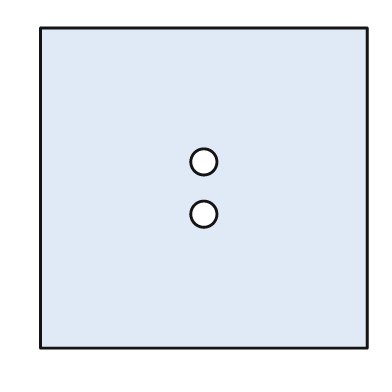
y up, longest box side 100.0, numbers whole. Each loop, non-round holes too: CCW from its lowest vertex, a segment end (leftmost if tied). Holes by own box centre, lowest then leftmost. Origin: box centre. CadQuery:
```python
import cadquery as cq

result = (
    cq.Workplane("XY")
    .moveTo(-50.0, -49.0)
    .lineTo(50.0, -49.0)
    .lineTo(50.0, 49.0)
    .lineTo(-50.0, 49.0)
    .close()
    .moveTo(0.0, -8.0)
    .circle(4.0)
    .moveTo(0.0, 8.0)
    .circle(4.0)
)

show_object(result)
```